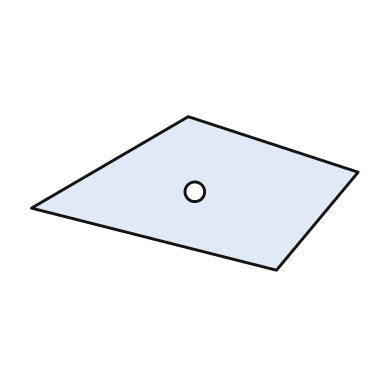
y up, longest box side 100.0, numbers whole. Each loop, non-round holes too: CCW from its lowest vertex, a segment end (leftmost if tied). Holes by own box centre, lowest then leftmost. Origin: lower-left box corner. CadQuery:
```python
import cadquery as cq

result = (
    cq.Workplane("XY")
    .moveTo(75.0, 0.0)
    .lineTo(100.0, 30.0)
    .lineTo(48.0, 47.0)
    .lineTo(0.0, 19.0)
    .close()
    .moveTo(50.0, 24.0)
    .circle(3.0)
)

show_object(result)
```